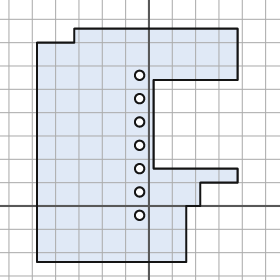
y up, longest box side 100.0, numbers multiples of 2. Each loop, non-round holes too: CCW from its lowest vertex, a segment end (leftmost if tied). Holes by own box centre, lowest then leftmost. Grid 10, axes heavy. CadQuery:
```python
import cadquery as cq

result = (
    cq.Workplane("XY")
    .moveTo(-48.0, -24.0)
    .lineTo(16.0, -24.0)
    .lineTo(16.0, 0.0)
    .lineTo(22.0, 0.0)
    .lineTo(22.0, 10.0)
    .lineTo(38.0, 10.0)
    .lineTo(38.0, 16.0)
    .lineTo(2.0, 16.0)
    .lineTo(2.0, 54.0)
    .lineTo(38.0, 54.0)
    .lineTo(38.0, 76.0)
    .lineTo(-32.0, 76.0)
    .lineTo(-32.0, 70.0)
    .lineTo(-48.0, 70.0)
    .close()
    .moveTo(-4.0, -4.0)
    .circle(2.0)
    .moveTo(-4.0, 6.0)
    .circle(2.0)
    .moveTo(-4.0, 16.0)
    .circle(2.0)
    .moveTo(-4.0, 26.0)
    .circle(2.0)
    .moveTo(-4.0, 36.0)
    .circle(2.0)
    .moveTo(-4.0, 46.0)
    .circle(2.0)
    .moveTo(-4.0, 56.0)
    .circle(2.0)
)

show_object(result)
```